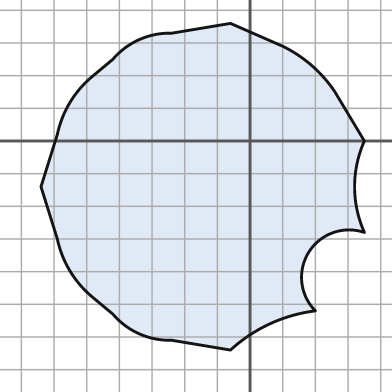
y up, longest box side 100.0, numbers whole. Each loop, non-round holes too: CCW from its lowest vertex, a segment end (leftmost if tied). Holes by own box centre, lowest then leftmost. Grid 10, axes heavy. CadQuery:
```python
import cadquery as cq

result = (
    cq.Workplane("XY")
    .moveTo(-6.0, -64.0)
    .threePointArc((6.0, -56.0), (20.0, -52.0))
    .threePointArc((18.0, -34.0), (35.0, -28.0))
    .threePointArc((32.0, -14.0), (35.0, 0.0))
    .lineTo(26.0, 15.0)
    .threePointArc((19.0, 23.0), (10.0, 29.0))
    .lineTo(-6.0, 36.0)
    .lineTo(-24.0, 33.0)
    .threePointArc((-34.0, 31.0), (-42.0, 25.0))
    .lineTo(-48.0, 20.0)
    .threePointArc((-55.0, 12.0), (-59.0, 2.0))
    .lineTo(-64.0, -14.0)
    .lineTo(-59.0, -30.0)
    .threePointArc((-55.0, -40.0), (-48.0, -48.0))
    .lineTo(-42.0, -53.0)
    .threePointArc((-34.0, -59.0), (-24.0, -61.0))
    .close()
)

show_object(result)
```